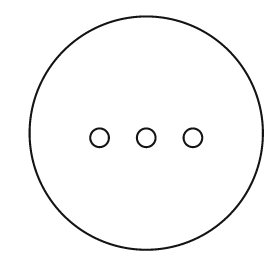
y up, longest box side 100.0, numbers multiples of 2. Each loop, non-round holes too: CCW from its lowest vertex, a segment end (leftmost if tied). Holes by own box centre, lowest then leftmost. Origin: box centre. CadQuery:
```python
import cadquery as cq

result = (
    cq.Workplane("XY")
    .moveTo(0.0, 0.0)
    .circle(50.0)
    .moveTo(-20.0, -2.0)
    .circle(4.0)
    .moveTo(0.0, -2.0)
    .circle(4.0)
    .moveTo(20.0, -2.0)
    .circle(4.0)
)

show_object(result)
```